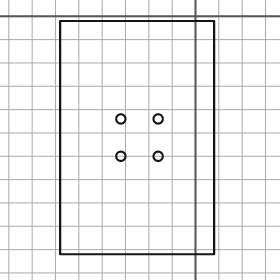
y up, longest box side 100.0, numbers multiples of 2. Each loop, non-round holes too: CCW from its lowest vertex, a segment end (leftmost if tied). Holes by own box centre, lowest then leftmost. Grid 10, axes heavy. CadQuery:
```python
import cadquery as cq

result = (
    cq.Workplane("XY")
    .moveTo(-58.0, -102.0)
    .lineTo(8.0, -102.0)
    .lineTo(8.0, -2.0)
    .lineTo(-58.0, -2.0)
    .close()
    .moveTo(-32.0, -60.0)
    .circle(2.0)
    .moveTo(-16.0, -60.0)
    .circle(2.0)
    .moveTo(-32.0, -44.0)
    .circle(2.0)
    .moveTo(-16.0, -44.0)
    .circle(2.0)
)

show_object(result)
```